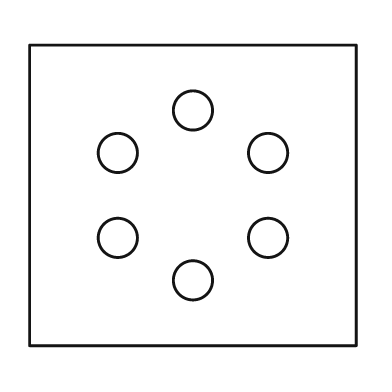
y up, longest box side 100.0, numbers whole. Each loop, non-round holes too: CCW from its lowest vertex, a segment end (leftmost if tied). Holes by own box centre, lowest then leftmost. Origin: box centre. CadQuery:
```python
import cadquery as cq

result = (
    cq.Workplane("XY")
    .moveTo(-50.0, -46.0)
    .lineTo(50.0, -46.0)
    .lineTo(50.0, 46.0)
    .lineTo(-50.0, 46.0)
    .close()
    .moveTo(0.0, -26.0)
    .circle(6.0)
    .moveTo(-23.0, -13.0)
    .circle(6.0)
    .moveTo(23.0, -13.0)
    .circle(6.0)
    .moveTo(-23.0, 13.0)
    .circle(6.0)
    .moveTo(23.0, 13.0)
    .circle(6.0)
    .moveTo(0.0, 26.0)
    .circle(6.0)
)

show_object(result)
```